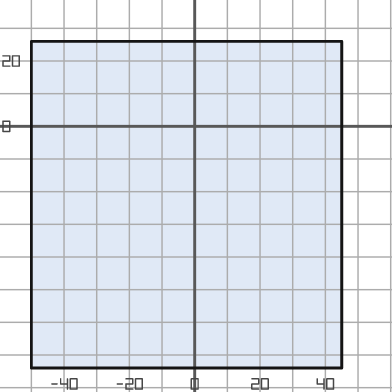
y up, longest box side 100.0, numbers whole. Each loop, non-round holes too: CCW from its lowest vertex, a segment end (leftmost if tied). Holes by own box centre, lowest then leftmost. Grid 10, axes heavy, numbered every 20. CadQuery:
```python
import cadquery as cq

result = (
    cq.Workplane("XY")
    .moveTo(-50.0, -74.0)
    .lineTo(45.0, -74.0)
    .lineTo(45.0, 26.0)
    .lineTo(-50.0, 26.0)
    .close()
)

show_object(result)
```